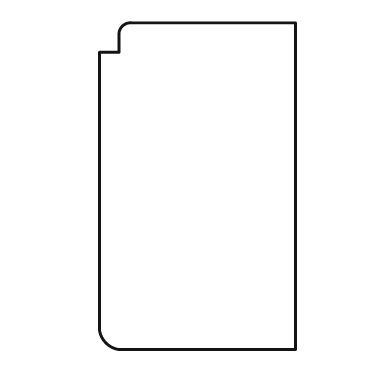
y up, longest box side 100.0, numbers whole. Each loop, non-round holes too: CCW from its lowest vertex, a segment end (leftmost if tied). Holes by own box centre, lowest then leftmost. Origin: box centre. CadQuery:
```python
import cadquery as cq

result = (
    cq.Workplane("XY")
    .moveTo(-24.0, -50.0)
    .lineTo(30.0, -50.0)
    .lineTo(30.0, 50.0)
    .lineTo(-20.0, 50.0)
    .threePointArc((-23.0, 49.0), (-24.0, 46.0))
    .lineTo(-24.0, 41.0)
    .lineTo(-30.0, 41.0)
    .lineTo(-30.0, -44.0)
    .threePointArc((-28.0, -48.0), (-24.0, -50.0))
    .close()
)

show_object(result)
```